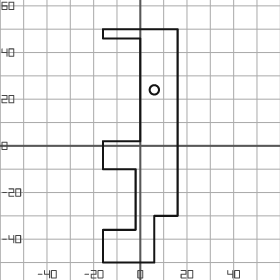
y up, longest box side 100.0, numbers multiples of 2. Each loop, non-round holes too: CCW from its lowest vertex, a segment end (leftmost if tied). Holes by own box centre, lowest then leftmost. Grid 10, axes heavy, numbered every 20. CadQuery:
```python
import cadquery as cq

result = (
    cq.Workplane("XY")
    .moveTo(-16.0, -50.0)
    .lineTo(6.0, -50.0)
    .lineTo(6.0, -30.0)
    .lineTo(16.0, -30.0)
    .lineTo(16.0, 50.0)
    .lineTo(-16.0, 50.0)
    .lineTo(-16.0, 46.0)
    .lineTo(0.0, 46.0)
    .lineTo(0.0, 2.0)
    .lineTo(-16.0, 2.0)
    .lineTo(-16.0, -10.0)
    .lineTo(-2.0, -10.0)
    .lineTo(-2.0, -36.0)
    .lineTo(-16.0, -36.0)
    .close()
    .moveTo(6.0, 24.0)
    .circle(2.0)
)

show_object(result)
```